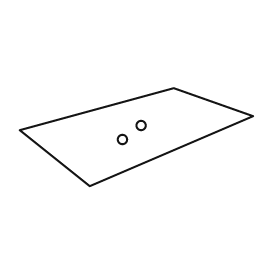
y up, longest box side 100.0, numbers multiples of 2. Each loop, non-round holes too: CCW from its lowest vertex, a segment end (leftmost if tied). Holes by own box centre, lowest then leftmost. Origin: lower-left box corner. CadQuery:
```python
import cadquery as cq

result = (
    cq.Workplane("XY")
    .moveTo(30.0, 0.0)
    .lineTo(100.0, 30.0)
    .lineTo(66.0, 42.0)
    .lineTo(0.0, 24.0)
    .close()
    .moveTo(44.0, 20.0)
    .circle(2.0)
    .moveTo(52.0, 26.0)
    .circle(2.0)
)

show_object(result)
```